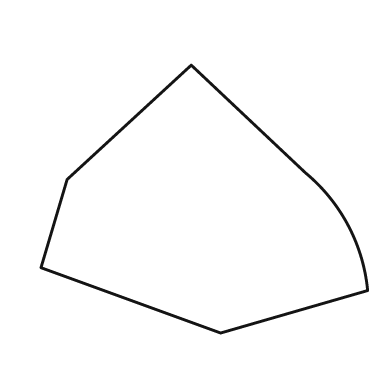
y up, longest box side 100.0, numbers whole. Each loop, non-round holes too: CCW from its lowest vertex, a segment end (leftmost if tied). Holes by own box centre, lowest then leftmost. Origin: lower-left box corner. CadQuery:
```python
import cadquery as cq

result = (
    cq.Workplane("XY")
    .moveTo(55.0, 0.0)
    .lineTo(100.0, 13.0)
    .threePointArc((94.0, 33.0), (81.0, 49.0))
    .lineTo(46.0, 82.0)
    .lineTo(8.0, 47.0)
    .lineTo(0.0, 20.0)
    .close()
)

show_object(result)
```